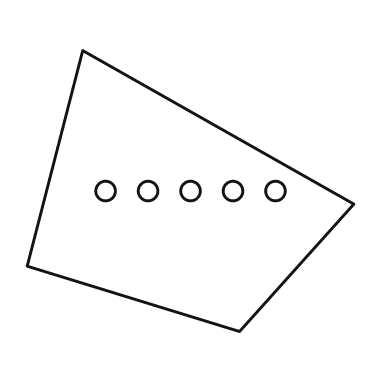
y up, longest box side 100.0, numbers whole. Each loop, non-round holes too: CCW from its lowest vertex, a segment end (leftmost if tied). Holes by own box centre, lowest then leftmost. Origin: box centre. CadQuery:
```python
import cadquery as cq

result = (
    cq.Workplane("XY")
    .moveTo(15.0, -43.0)
    .lineTo(50.0, -4.0)
    .lineTo(-33.0, 43.0)
    .lineTo(-50.0, -23.0)
    .close()
    .moveTo(-26.0, 0.0)
    .circle(3.0)
    .moveTo(-13.0, 0.0)
    .circle(3.0)
    .moveTo(0.0, 0.0)
    .circle(3.0)
    .moveTo(13.0, 0.0)
    .circle(3.0)
    .moveTo(26.0, 0.0)
    .circle(3.0)
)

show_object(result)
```